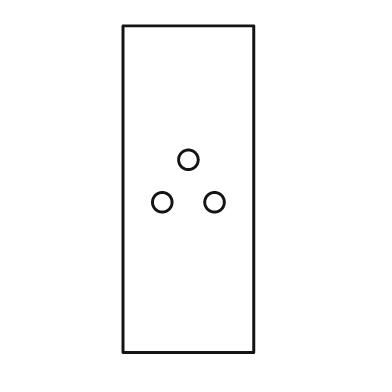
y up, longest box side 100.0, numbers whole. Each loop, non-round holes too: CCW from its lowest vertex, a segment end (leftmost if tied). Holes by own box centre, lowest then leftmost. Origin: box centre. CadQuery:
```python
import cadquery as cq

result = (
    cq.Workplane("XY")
    .moveTo(-20.0, -50.0)
    .lineTo(20.0, -50.0)
    .lineTo(20.0, 50.0)
    .lineTo(-20.0, 50.0)
    .close()
    .moveTo(-8.0, -4.0)
    .circle(3.0)
    .moveTo(8.0, -4.0)
    .circle(3.0)
    .moveTo(0.0, 9.0)
    .circle(3.0)
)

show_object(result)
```